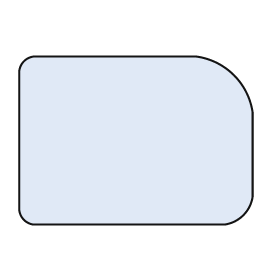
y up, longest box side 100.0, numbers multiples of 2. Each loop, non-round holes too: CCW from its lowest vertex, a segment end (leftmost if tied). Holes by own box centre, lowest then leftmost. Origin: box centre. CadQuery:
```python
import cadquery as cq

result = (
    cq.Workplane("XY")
    .moveTo(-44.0, -36.0)
    .lineTo(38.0, -36.0)
    .threePointArc((46.0, -32.0), (50.0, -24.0))
    .lineTo(50.0, 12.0)
    .threePointArc((42.0, 28.0), (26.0, 36.0))
    .lineTo(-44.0, 36.0)
    .threePointArc((-48.0, 34.0), (-50.0, 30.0))
    .lineTo(-50.0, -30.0)
    .threePointArc((-48.0, -34.0), (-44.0, -36.0))
    .close()
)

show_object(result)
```